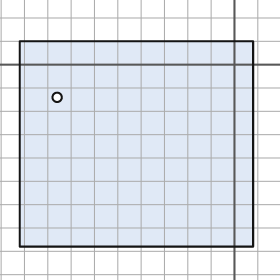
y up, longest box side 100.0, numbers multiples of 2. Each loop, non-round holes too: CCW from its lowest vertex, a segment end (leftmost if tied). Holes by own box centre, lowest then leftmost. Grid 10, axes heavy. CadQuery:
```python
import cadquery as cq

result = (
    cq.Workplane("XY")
    .moveTo(-92.0, -78.0)
    .lineTo(8.0, -78.0)
    .lineTo(8.0, 10.0)
    .lineTo(-92.0, 10.0)
    .close()
    .moveTo(-76.0, -14.0)
    .circle(2.0)
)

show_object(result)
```